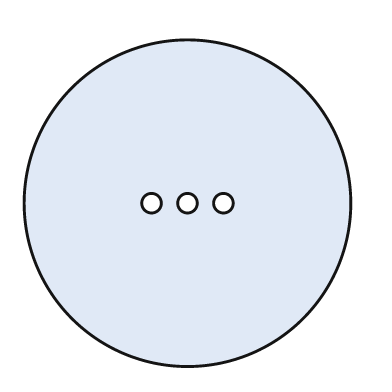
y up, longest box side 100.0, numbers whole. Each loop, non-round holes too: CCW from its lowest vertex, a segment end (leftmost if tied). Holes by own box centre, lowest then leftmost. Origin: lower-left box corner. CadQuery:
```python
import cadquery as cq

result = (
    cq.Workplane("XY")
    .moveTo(50.0, 50.0)
    .circle(50.0)
    .moveTo(39.0, 50.0)
    .circle(3.0)
    .moveTo(50.0, 50.0)
    .circle(3.0)
    .moveTo(61.0, 50.0)
    .circle(3.0)
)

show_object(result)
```